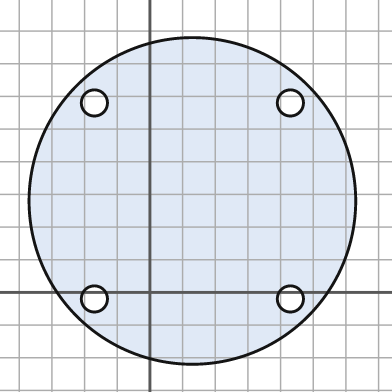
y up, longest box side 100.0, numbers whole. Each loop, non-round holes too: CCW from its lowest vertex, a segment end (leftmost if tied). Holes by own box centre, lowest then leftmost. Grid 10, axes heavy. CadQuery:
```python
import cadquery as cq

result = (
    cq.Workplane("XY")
    .moveTo(13.0, 28.0)
    .circle(50.0)
    .moveTo(-17.0, -2.0)
    .circle(4.0)
    .moveTo(43.0, -2.0)
    .circle(4.0)
    .moveTo(-17.0, 58.0)
    .circle(4.0)
    .moveTo(43.0, 58.0)
    .circle(4.0)
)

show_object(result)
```